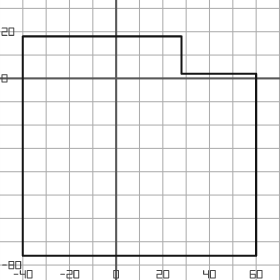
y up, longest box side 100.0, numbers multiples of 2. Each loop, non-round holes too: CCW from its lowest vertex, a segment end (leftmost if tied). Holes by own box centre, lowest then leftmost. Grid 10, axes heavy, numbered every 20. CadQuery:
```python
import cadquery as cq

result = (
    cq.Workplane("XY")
    .moveTo(-40.0, -76.0)
    .lineTo(60.0, -76.0)
    .lineTo(60.0, 2.0)
    .lineTo(28.0, 2.0)
    .lineTo(28.0, 18.0)
    .lineTo(-40.0, 18.0)
    .close()
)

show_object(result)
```